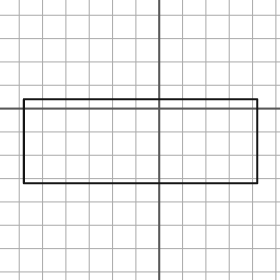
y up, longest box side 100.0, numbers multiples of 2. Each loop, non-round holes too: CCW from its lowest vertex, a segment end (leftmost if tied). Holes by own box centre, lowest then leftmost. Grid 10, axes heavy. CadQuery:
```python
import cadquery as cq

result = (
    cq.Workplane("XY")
    .moveTo(-58.0, -32.0)
    .lineTo(42.0, -32.0)
    .lineTo(42.0, 4.0)
    .lineTo(-58.0, 4.0)
    .close()
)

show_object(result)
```